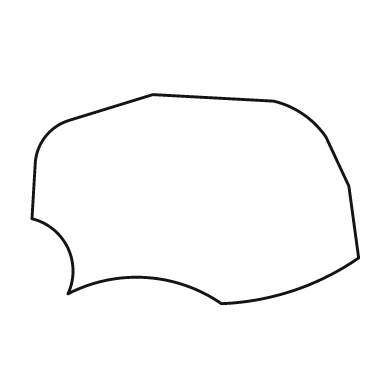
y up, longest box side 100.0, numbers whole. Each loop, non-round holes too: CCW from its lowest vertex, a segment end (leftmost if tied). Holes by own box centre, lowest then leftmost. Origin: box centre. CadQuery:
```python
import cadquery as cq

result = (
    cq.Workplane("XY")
    .moveTo(8.0, -32.0)
    .threePointArc((30.0, -28.0), (50.0, -18.0))
    .lineTo(47.0, 4.0)
    .lineTo(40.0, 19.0)
    .threePointArc((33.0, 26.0), (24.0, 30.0))
    .lineTo(-13.0, 32.0)
    .lineTo(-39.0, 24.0)
    .threePointArc((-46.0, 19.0), (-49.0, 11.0))
    .lineTo(-50.0, -6.0)
    .threePointArc((-39.0, -15.0), (-39.0, -29.0))
    .threePointArc((-15.0, -24.0), (8.0, -32.0))
    .close()
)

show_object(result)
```